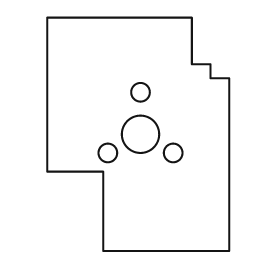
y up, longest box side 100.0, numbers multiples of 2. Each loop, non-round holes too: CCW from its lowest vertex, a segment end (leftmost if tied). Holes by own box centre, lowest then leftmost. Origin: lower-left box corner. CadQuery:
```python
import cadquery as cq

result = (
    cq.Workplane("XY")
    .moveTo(24.0, 0.0)
    .lineTo(78.0, 0.0)
    .lineTo(78.0, 74.0)
    .lineTo(70.0, 74.0)
    .lineTo(70.0, 80.0)
    .lineTo(62.0, 80.0)
    .lineTo(62.0, 100.0)
    .lineTo(0.0, 100.0)
    .lineTo(0.0, 34.0)
    .lineTo(24.0, 34.0)
    .close()
    .moveTo(26.0, 42.0)
    .circle(4.0)
    .moveTo(54.0, 42.0)
    .circle(4.0)
    .moveTo(40.0, 50.0)
    .circle(8.0)
    .moveTo(40.0, 68.0)
    .circle(4.0)
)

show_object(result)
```